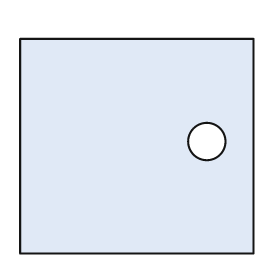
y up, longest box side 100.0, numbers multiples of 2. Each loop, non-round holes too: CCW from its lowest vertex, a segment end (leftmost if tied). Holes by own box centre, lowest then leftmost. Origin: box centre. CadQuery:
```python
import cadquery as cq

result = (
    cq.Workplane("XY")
    .moveTo(-50.0, -46.0)
    .lineTo(50.0, -46.0)
    .lineTo(50.0, 46.0)
    .lineTo(-50.0, 46.0)
    .close()
    .moveTo(30.0, 2.0)
    .circle(8.0)
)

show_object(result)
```